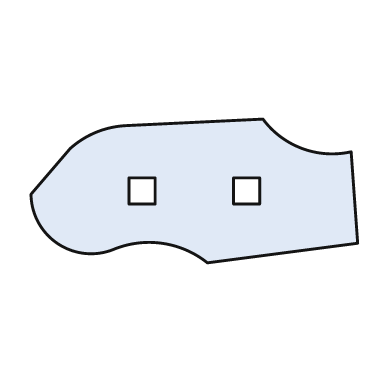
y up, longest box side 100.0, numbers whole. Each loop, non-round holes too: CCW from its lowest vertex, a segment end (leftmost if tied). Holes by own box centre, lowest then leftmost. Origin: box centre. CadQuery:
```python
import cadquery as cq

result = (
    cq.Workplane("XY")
    .moveTo(4.0, -22.0)
    .lineTo(50.0, -16.0)
    .lineTo(48.0, 12.0)
    .threePointArc((33.0, 13.0), (21.0, 22.0))
    .lineTo(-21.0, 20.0)
    .threePointArc((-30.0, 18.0), (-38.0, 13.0))
    .lineTo(-50.0, -1.0)
    .threePointArc((-42.0, -16.0), (-25.0, -18.0))
    .threePointArc((-10.0, -16.0), (4.0, -22.0))
    .close()
    .moveTo(-20.0, -4.0)
    .lineTo(-12.0, -4.0)
    .lineTo(-12.0, 4.0)
    .lineTo(-20.0, 4.0)
    .close()
    .moveTo(12.0, -4.0)
    .lineTo(20.0, -4.0)
    .lineTo(20.0, 4.0)
    .lineTo(12.0, 4.0)
    .close()
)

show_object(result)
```